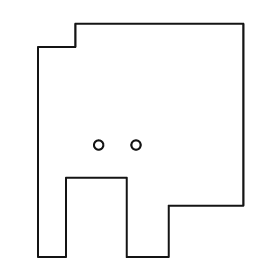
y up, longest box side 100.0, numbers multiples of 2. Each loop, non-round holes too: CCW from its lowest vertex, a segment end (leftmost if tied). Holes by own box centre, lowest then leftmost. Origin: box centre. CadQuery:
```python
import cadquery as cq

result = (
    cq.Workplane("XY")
    .moveTo(-44.0, -50.0)
    .lineTo(-32.0, -50.0)
    .lineTo(-32.0, -16.0)
    .lineTo(-6.0, -16.0)
    .lineTo(-6.0, -50.0)
    .lineTo(12.0, -50.0)
    .lineTo(12.0, -28.0)
    .lineTo(44.0, -28.0)
    .lineTo(44.0, 50.0)
    .lineTo(-28.0, 50.0)
    .lineTo(-28.0, 40.0)
    .lineTo(-44.0, 40.0)
    .close()
    .moveTo(-18.0, -2.0)
    .circle(2.0)
    .moveTo(-2.0, -2.0)
    .circle(2.0)
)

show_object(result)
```